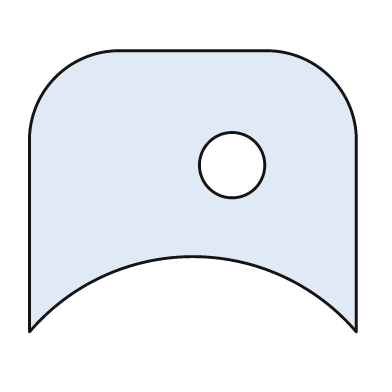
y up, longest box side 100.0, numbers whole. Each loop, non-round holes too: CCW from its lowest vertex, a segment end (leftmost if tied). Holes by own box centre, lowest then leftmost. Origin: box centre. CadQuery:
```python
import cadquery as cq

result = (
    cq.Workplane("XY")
    .moveTo(-50.0, -43.0)
    .threePointArc((0.0, -20.0), (50.0, -43.0))
    .lineTo(50.0, 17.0)
    .threePointArc((42.0, 35.0), (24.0, 43.0))
    .lineTo(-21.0, 43.0)
    .threePointArc((-42.0, 35.0), (-50.0, 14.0))
    .close()
    .moveTo(12.0, 8.0)
    .circle(10.0)
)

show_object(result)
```